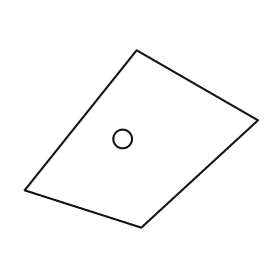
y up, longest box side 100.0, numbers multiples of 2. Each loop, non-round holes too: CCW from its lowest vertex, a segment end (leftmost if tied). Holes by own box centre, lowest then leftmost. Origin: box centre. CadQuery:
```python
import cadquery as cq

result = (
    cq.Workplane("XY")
    .moveTo(0.0, -38.0)
    .lineTo(50.0, 8.0)
    .lineTo(-2.0, 38.0)
    .lineTo(-50.0, -22.0)
    .close()
    .moveTo(-8.0, 0.0)
    .circle(4.0)
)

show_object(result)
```